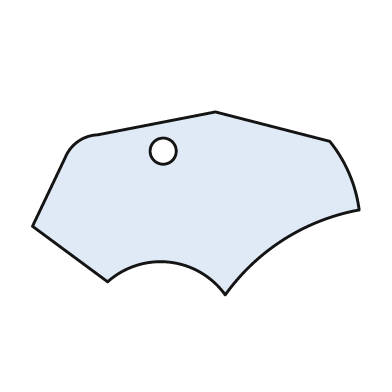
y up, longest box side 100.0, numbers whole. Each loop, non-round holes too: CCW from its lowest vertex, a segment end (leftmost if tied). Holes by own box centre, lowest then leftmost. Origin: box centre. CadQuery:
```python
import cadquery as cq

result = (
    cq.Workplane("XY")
    .moveTo(9.0, -28.0)
    .threePointArc((27.0, -11.0), (50.0, -2.0))
    .threePointArc((47.0, 9.0), (41.0, 19.0))
    .lineTo(6.0, 28.0)
    .lineTo(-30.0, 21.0)
    .threePointArc((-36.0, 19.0), (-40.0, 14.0))
    .lineTo(-50.0, -7.0)
    .lineTo(-27.0, -24.0)
    .threePointArc((-8.0, -18.0), (9.0, -28.0))
    .close()
    .moveTo(-10.0, 16.0)
    .circle(4.0)
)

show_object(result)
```